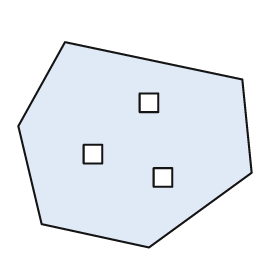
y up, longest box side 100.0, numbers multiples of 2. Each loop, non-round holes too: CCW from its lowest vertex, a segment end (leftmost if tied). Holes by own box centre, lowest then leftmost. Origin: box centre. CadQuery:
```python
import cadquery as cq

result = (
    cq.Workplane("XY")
    .moveTo(6.0, -44.0)
    .lineTo(50.0, -12.0)
    .lineTo(46.0, 28.0)
    .lineTo(-30.0, 44.0)
    .lineTo(-50.0, 8.0)
    .lineTo(-40.0, -34.0)
    .close()
    .moveTo(8.0, -18.0)
    .lineTo(16.0, -18.0)
    .lineTo(16.0, -10.0)
    .lineTo(8.0, -10.0)
    .close()
    .moveTo(-22.0, -8.0)
    .lineTo(-14.0, -8.0)
    .lineTo(-14.0, 0.0)
    .lineTo(-22.0, 0.0)
    .close()
    .moveTo(2.0, 14.0)
    .lineTo(10.0, 14.0)
    .lineTo(10.0, 22.0)
    .lineTo(2.0, 22.0)
    .close()
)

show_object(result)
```